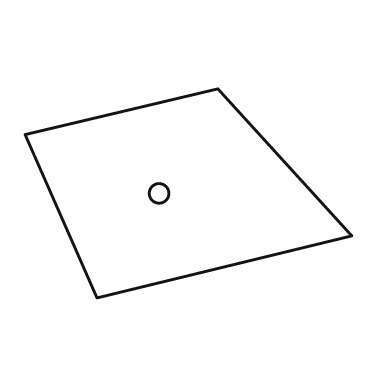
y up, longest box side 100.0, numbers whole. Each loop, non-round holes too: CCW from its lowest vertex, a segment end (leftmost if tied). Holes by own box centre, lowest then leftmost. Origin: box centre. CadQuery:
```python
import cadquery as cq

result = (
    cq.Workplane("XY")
    .moveTo(-28.0, -32.0)
    .lineTo(50.0, -13.0)
    .lineTo(9.0, 32.0)
    .lineTo(-50.0, 18.0)
    .close()
    .moveTo(-9.0, 0.0)
    .circle(3.0)
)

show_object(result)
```